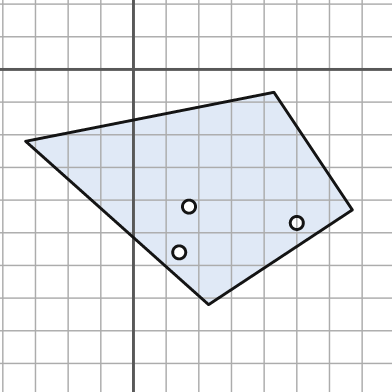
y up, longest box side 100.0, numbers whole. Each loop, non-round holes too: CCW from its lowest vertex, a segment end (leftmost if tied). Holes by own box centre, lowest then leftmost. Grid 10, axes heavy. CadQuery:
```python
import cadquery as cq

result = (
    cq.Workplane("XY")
    .moveTo(23.0, -72.0)
    .lineTo(67.0, -43.0)
    .lineTo(43.0, -7.0)
    .lineTo(-33.0, -22.0)
    .close()
    .moveTo(14.0, -56.0)
    .circle(2.0)
    .moveTo(50.0, -47.0)
    .circle(2.0)
    .moveTo(17.0, -42.0)
    .circle(2.0)
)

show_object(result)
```